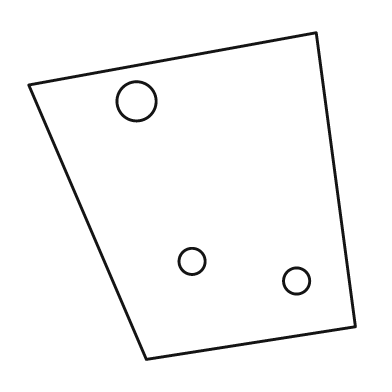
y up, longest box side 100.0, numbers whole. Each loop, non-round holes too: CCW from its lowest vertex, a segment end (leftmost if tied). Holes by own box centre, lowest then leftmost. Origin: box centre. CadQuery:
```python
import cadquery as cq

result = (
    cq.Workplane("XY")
    .moveTo(-14.0, -50.0)
    .lineTo(50.0, -40.0)
    .lineTo(38.0, 50.0)
    .lineTo(-50.0, 34.0)
    .close()
    .moveTo(32.0, -26.0)
    .circle(4.0)
    .moveTo(0.0, -20.0)
    .circle(4.0)
    .moveTo(-17.0, 29.0)
    .circle(6.0)
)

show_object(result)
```